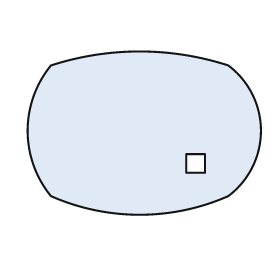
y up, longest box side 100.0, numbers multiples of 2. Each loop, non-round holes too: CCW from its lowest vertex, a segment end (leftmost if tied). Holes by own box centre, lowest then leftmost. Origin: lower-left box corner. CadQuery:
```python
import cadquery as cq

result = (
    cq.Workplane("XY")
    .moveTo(10.0, 8.0)
    .threePointArc((48.0, 0.0), (86.0, 8.0))
    .threePointArc((100.0, 36.0), (86.0, 64.0))
    .threePointArc((48.0, 70.0), (10.0, 64.0))
    .threePointArc((0.0, 36.0), (10.0, 8.0))
    .close()
    .moveTo(68.0, 18.0)
    .lineTo(76.0, 18.0)
    .lineTo(76.0, 26.0)
    .lineTo(68.0, 26.0)
    .close()
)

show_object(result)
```